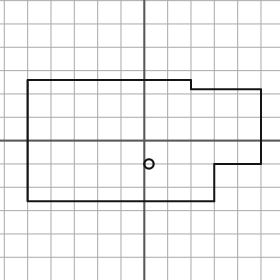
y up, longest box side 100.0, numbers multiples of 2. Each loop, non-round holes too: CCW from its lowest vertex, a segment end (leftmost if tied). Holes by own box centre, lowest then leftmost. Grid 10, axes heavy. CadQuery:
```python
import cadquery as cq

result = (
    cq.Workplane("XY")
    .moveTo(-50.0, -26.0)
    .lineTo(30.0, -26.0)
    .lineTo(30.0, -10.0)
    .lineTo(50.0, -10.0)
    .lineTo(50.0, 22.0)
    .lineTo(20.0, 22.0)
    .lineTo(20.0, 26.0)
    .lineTo(-50.0, 26.0)
    .close()
    .moveTo(2.0, -10.0)
    .circle(2.0)
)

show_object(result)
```